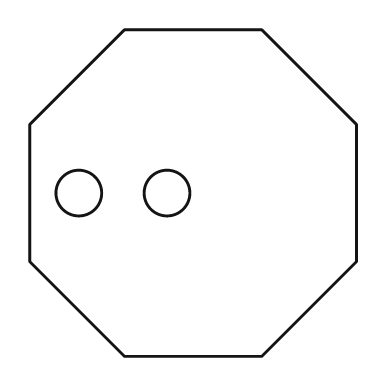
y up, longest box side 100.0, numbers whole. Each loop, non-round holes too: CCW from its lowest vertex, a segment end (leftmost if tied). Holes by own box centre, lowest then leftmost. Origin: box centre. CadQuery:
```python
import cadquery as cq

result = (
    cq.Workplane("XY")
    .moveTo(-21.0, -50.0)
    .lineTo(21.0, -50.0)
    .lineTo(50.0, -21.0)
    .lineTo(50.0, 21.0)
    .lineTo(21.0, 50.0)
    .lineTo(-21.0, 50.0)
    .lineTo(-50.0, 21.0)
    .lineTo(-50.0, -21.0)
    .close()
    .moveTo(-35.0, 0.0)
    .circle(7.0)
    .moveTo(-8.0, 0.0)
    .circle(7.0)
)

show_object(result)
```